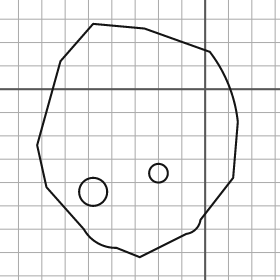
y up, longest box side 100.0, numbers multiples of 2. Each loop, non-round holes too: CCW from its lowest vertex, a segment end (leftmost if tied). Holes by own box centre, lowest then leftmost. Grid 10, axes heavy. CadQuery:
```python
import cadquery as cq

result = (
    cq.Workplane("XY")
    .moveTo(-28.0, -72.0)
    .lineTo(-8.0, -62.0)
    .threePointArc((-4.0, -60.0), (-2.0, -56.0))
    .lineTo(12.0, -38.0)
    .lineTo(14.0, -14.0)
    .threePointArc((10.0, 2.0), (2.0, 16.0))
    .lineTo(-26.0, 26.0)
    .lineTo(-48.0, 28.0)
    .lineTo(-62.0, 12.0)
    .lineTo(-72.0, -24.0)
    .lineTo(-68.0, -42.0)
    .lineTo(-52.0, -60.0)
    .threePointArc((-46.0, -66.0), (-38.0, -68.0))
    .close()
    .moveTo(-48.0, -44.0)
    .circle(6.0)
    .moveTo(-20.0, -36.0)
    .circle(4.0)
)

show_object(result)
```